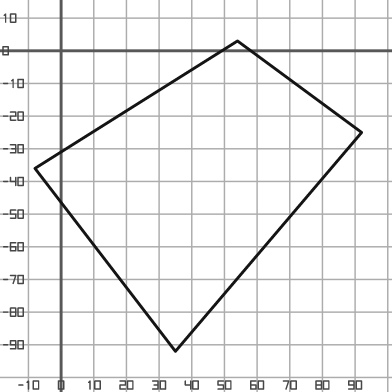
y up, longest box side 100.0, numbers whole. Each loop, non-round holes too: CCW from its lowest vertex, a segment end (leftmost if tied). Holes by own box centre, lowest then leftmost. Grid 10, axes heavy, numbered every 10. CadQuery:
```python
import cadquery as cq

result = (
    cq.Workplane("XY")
    .moveTo(35.0, -92.0)
    .lineTo(92.0, -25.0)
    .lineTo(54.0, 3.0)
    .lineTo(-8.0, -36.0)
    .close()
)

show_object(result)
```